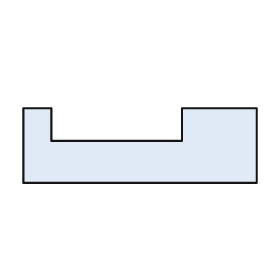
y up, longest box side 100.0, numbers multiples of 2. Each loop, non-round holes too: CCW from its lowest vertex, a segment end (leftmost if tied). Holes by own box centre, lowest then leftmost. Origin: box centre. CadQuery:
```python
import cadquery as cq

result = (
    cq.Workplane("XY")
    .moveTo(-50.0, -16.0)
    .lineTo(50.0, -16.0)
    .lineTo(50.0, 16.0)
    .lineTo(18.0, 16.0)
    .lineTo(18.0, 2.0)
    .lineTo(-38.0, 2.0)
    .lineTo(-38.0, 16.0)
    .lineTo(-50.0, 16.0)
    .close()
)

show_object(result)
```